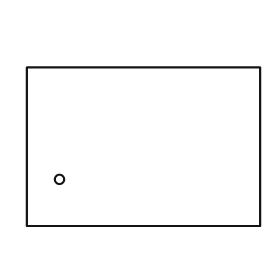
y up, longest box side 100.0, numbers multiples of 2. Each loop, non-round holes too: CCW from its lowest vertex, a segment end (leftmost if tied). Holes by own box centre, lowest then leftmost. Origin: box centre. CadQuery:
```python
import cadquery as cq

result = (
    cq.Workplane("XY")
    .moveTo(-50.0, -34.0)
    .lineTo(50.0, -34.0)
    .lineTo(50.0, 34.0)
    .lineTo(-50.0, 34.0)
    .close()
    .moveTo(-36.0, -14.0)
    .circle(2.0)
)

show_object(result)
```